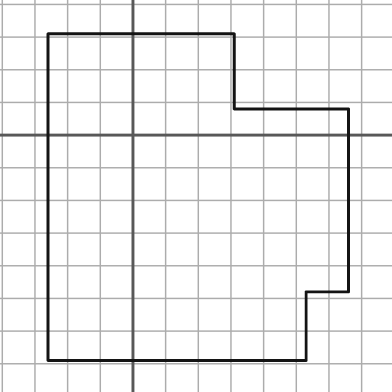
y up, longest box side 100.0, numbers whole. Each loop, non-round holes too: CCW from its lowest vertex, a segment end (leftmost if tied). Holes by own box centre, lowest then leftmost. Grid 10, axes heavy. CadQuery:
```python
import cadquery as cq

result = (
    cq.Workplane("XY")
    .moveTo(-26.0, -69.0)
    .lineTo(53.0, -69.0)
    .lineTo(53.0, -48.0)
    .lineTo(66.0, -48.0)
    .lineTo(66.0, 8.0)
    .lineTo(31.0, 8.0)
    .lineTo(31.0, 31.0)
    .lineTo(-26.0, 31.0)
    .close()
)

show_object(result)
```